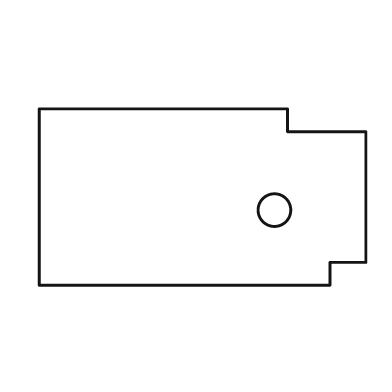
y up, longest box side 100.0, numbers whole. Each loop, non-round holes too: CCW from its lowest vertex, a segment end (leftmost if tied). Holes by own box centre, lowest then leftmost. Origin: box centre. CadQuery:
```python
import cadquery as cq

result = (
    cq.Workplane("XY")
    .moveTo(-50.0, -27.0)
    .lineTo(39.0, -27.0)
    .lineTo(39.0, -20.0)
    .lineTo(50.0, -20.0)
    .lineTo(50.0, 20.0)
    .lineTo(26.0, 20.0)
    .lineTo(26.0, 27.0)
    .lineTo(-50.0, 27.0)
    .close()
    .moveTo(22.0, -4.0)
    .circle(5.0)
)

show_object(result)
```